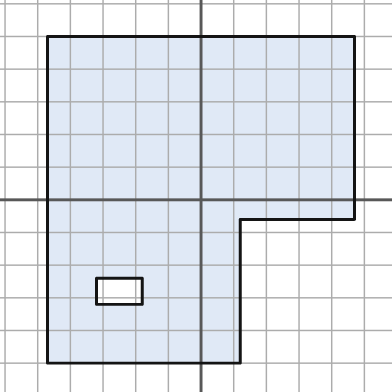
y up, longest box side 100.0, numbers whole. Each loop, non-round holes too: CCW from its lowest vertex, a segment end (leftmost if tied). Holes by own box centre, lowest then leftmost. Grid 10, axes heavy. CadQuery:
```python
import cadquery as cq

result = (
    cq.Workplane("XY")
    .moveTo(-47.0, -50.0)
    .lineTo(12.0, -50.0)
    .lineTo(12.0, -6.0)
    .lineTo(47.0, -6.0)
    .lineTo(47.0, 50.0)
    .lineTo(-47.0, 50.0)
    .close()
    .moveTo(-32.0, -32.0)
    .lineTo(-18.0, -32.0)
    .lineTo(-18.0, -24.0)
    .lineTo(-32.0, -24.0)
    .close()
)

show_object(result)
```